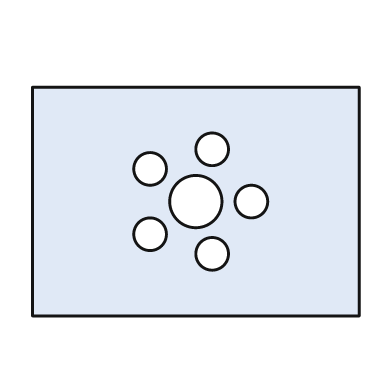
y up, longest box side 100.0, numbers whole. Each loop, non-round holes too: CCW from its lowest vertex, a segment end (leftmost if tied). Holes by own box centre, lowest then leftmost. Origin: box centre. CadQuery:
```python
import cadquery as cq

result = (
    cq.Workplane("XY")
    .moveTo(-50.0, -35.0)
    .lineTo(50.0, -35.0)
    .lineTo(50.0, 35.0)
    .lineTo(-50.0, 35.0)
    .close()
    .moveTo(5.0, -16.0)
    .circle(5.0)
    .moveTo(-14.0, -10.0)
    .circle(5.0)
    .moveTo(0.0, 0.0)
    .circle(8.0)
    .moveTo(17.0, 0.0)
    .circle(5.0)
    .moveTo(-14.0, 10.0)
    .circle(5.0)
    .moveTo(5.0, 16.0)
    .circle(5.0)
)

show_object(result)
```